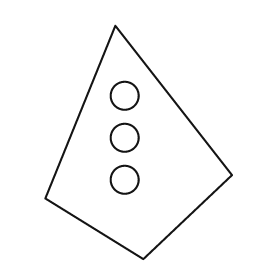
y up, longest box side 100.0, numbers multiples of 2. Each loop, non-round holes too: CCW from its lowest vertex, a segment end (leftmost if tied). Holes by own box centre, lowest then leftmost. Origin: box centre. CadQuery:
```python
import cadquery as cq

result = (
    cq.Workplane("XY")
    .moveTo(2.0, -50.0)
    .lineTo(40.0, -14.0)
    .lineTo(-10.0, 50.0)
    .lineTo(-40.0, -24.0)
    .close()
    .moveTo(-6.0, -16.0)
    .circle(6.0)
    .moveTo(-6.0, 2.0)
    .circle(6.0)
    .moveTo(-6.0, 20.0)
    .circle(6.0)
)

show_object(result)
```